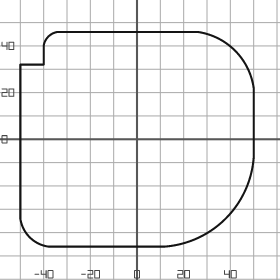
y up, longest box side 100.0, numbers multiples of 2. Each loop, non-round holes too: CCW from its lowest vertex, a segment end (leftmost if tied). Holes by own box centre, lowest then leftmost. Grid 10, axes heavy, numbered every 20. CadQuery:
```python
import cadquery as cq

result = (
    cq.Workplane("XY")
    .moveTo(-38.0, -46.0)
    .lineTo(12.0, -46.0)
    .threePointArc((38.0, -34.0), (50.0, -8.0))
    .lineTo(50.0, 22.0)
    .threePointArc((42.0, 38.0), (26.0, 46.0))
    .lineTo(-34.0, 46.0)
    .threePointArc((-38.0, 44.0), (-40.0, 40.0))
    .lineTo(-40.0, 32.0)
    .lineTo(-50.0, 32.0)
    .lineTo(-50.0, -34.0)
    .threePointArc((-46.0, -42.0), (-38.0, -46.0))
    .close()
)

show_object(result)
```